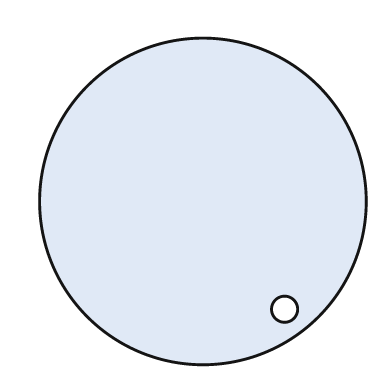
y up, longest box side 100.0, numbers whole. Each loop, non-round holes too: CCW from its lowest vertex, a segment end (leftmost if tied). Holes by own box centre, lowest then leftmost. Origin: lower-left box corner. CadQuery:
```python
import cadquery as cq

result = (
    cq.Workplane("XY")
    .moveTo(50.0, 50.0)
    .circle(50.0)
    .moveTo(75.0, 17.0)
    .circle(4.0)
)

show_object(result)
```